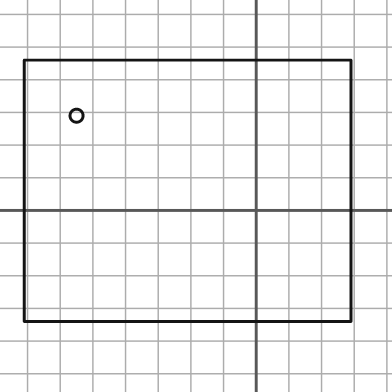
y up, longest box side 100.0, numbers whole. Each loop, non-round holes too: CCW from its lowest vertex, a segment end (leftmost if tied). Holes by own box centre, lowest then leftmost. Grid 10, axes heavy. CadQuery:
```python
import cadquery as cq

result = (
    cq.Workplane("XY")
    .moveTo(-71.0, -34.0)
    .lineTo(29.0, -34.0)
    .lineTo(29.0, 46.0)
    .lineTo(-71.0, 46.0)
    .close()
    .moveTo(-55.0, 29.0)
    .circle(2.0)
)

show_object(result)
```